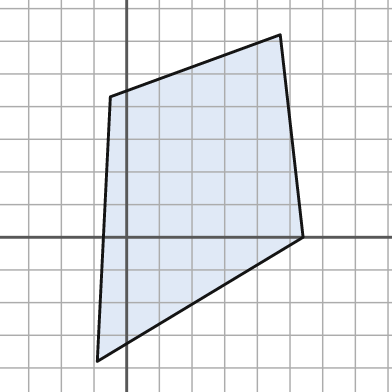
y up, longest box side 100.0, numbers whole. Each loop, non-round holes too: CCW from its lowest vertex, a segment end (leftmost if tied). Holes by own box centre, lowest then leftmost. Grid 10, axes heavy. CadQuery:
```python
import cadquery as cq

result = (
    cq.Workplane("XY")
    .moveTo(-9.0, -38.0)
    .lineTo(54.0, 0.0)
    .lineTo(47.0, 62.0)
    .lineTo(-5.0, 43.0)
    .close()
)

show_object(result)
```